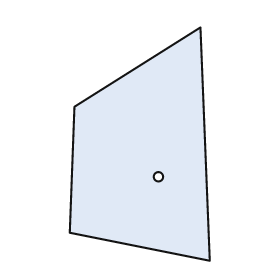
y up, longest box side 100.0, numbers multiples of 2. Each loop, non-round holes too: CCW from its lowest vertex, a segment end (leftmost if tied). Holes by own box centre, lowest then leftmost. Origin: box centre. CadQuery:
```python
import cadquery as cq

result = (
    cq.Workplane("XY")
    .moveTo(30.0, -50.0)
    .lineTo(26.0, 50.0)
    .lineTo(-28.0, 16.0)
    .lineTo(-30.0, -38.0)
    .close()
    .moveTo(8.0, -14.0)
    .circle(2.0)
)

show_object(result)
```